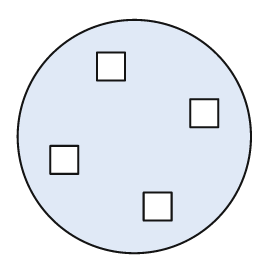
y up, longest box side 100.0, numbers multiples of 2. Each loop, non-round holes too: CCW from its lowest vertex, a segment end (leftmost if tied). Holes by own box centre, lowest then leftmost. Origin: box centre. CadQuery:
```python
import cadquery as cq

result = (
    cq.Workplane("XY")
    .moveTo(0.0, 0.0)
    .circle(50.0)
    .moveTo(4.0, -36.0)
    .lineTo(16.0, -36.0)
    .lineTo(16.0, -24.0)
    .lineTo(4.0, -24.0)
    .close()
    .moveTo(-36.0, -16.0)
    .lineTo(-24.0, -16.0)
    .lineTo(-24.0, -4.0)
    .lineTo(-36.0, -4.0)
    .close()
    .moveTo(24.0, 4.0)
    .lineTo(36.0, 4.0)
    .lineTo(36.0, 16.0)
    .lineTo(24.0, 16.0)
    .close()
    .moveTo(-16.0, 24.0)
    .lineTo(-4.0, 24.0)
    .lineTo(-4.0, 36.0)
    .lineTo(-16.0, 36.0)
    .close()
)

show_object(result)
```